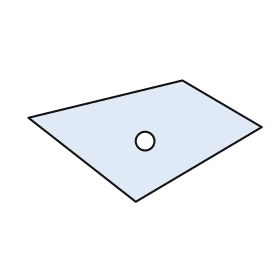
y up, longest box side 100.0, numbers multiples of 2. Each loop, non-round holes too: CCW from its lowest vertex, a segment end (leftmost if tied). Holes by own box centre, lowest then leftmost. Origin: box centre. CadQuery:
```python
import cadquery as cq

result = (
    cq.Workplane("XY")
    .moveTo(-4.0, -26.0)
    .lineTo(50.0, 6.0)
    .lineTo(16.0, 26.0)
    .lineTo(-50.0, 10.0)
    .close()
    .moveTo(0.0, 0.0)
    .circle(4.0)
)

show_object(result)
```